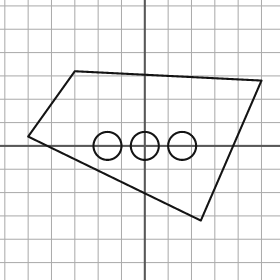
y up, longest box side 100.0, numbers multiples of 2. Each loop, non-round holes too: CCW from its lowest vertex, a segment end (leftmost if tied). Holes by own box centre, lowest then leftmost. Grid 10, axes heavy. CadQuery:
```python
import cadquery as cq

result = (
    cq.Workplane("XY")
    .moveTo(24.0, -32.0)
    .lineTo(50.0, 28.0)
    .lineTo(-30.0, 32.0)
    .lineTo(-50.0, 4.0)
    .close()
    .moveTo(-16.0, 0.0)
    .circle(6.0)
    .moveTo(0.0, 0.0)
    .circle(6.0)
    .moveTo(16.0, 0.0)
    .circle(6.0)
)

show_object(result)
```